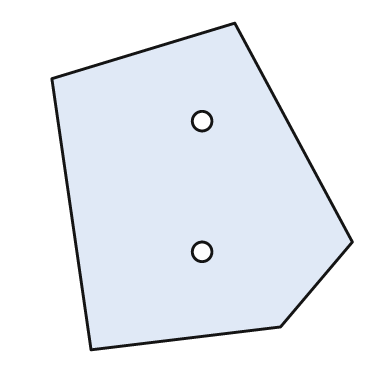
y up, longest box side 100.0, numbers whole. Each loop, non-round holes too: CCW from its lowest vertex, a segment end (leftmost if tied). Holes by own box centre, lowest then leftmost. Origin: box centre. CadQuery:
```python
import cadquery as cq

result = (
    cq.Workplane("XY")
    .moveTo(-34.0, -50.0)
    .lineTo(24.0, -43.0)
    .lineTo(46.0, -17.0)
    .lineTo(10.0, 50.0)
    .lineTo(-46.0, 33.0)
    .close()
    .moveTo(0.0, -20.0)
    .circle(3.0)
    .moveTo(0.0, 20.0)
    .circle(3.0)
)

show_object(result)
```